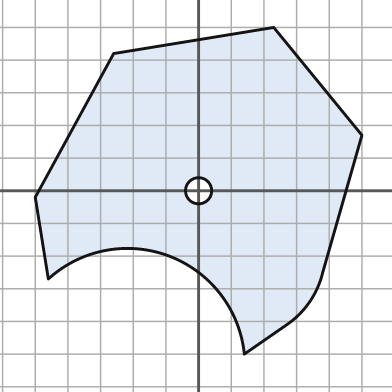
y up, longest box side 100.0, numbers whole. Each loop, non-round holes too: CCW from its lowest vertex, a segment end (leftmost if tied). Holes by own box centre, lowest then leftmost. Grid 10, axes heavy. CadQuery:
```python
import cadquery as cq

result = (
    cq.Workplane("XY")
    .moveTo(14.0, -50.0)
    .lineTo(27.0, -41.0)
    .threePointArc((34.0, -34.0), (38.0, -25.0))
    .lineTo(50.0, 17.0)
    .lineTo(23.0, 50.0)
    .lineTo(-26.0, 42.0)
    .lineTo(-50.0, -2.0)
    .lineTo(-46.0, -27.0)
    .threePointArc((-9.0, -20.0), (14.0, -50.0))
    .close()
    .moveTo(0.0, 0.0)
    .circle(4.0)
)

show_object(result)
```